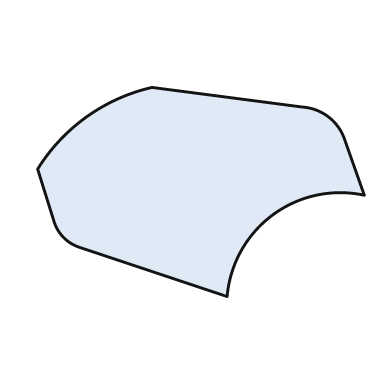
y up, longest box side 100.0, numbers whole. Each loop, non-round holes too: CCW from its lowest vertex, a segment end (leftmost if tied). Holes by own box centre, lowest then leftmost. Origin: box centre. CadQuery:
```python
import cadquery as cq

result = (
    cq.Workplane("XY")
    .moveTo(8.0, -32.0)
    .threePointArc((22.0, -7.0), (50.0, -1.0))
    .lineTo(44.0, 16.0)
    .threePointArc((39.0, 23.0), (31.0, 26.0))
    .lineTo(-15.0, 32.0)
    .threePointArc((-35.0, 23.0), (-50.0, 7.0))
    .lineTo(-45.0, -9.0)
    .threePointArc((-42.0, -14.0), (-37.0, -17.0))
    .close()
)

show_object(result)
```